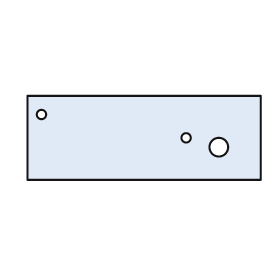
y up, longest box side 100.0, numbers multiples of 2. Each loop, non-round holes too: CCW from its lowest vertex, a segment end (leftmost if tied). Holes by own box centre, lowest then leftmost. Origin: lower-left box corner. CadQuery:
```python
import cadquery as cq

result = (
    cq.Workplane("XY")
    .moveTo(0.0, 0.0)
    .lineTo(100.0, 0.0)
    .lineTo(100.0, 36.0)
    .lineTo(0.0, 36.0)
    .close()
    .moveTo(82.0, 14.0)
    .circle(4.0)
    .moveTo(68.0, 18.0)
    .circle(2.0)
    .moveTo(6.0, 28.0)
    .circle(2.0)
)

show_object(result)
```